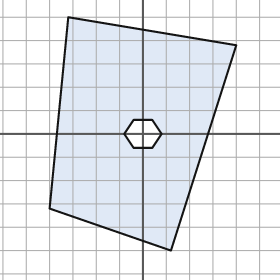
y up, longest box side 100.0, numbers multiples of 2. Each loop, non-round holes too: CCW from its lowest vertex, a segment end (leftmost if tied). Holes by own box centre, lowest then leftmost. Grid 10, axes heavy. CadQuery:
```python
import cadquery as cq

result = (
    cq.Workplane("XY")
    .moveTo(12.0, -50.0)
    .lineTo(40.0, 38.0)
    .lineTo(-32.0, 50.0)
    .lineTo(-40.0, -32.0)
    .close()
    .moveTo(-4.0, -6.0)
    .lineTo(4.0, -6.0)
    .lineTo(8.0, 0.0)
    .lineTo(4.0, 6.0)
    .lineTo(-4.0, 6.0)
    .lineTo(-8.0, 0.0)
    .close()
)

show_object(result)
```